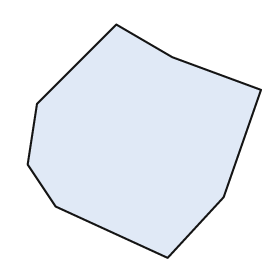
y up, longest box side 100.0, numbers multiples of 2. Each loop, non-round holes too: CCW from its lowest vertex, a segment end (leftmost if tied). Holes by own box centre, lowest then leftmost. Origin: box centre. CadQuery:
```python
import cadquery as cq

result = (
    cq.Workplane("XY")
    .moveTo(10.0, -50.0)
    .lineTo(34.0, -24.0)
    .lineTo(50.0, 22.0)
    .lineTo(12.0, 36.0)
    .lineTo(-12.0, 50.0)
    .lineTo(-46.0, 16.0)
    .lineTo(-50.0, -10.0)
    .lineTo(-38.0, -28.0)
    .close()
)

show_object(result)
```